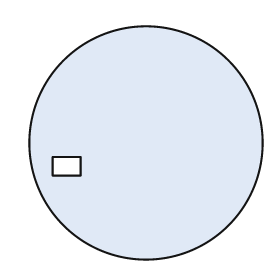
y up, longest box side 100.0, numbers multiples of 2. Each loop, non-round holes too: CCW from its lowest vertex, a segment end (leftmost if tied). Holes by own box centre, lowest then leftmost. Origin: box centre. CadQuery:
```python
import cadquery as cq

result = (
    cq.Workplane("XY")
    .moveTo(0.0, 0.0)
    .circle(50.0)
    .moveTo(-40.0, -14.0)
    .lineTo(-28.0, -14.0)
    .lineTo(-28.0, -6.0)
    .lineTo(-40.0, -6.0)
    .close()
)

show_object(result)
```